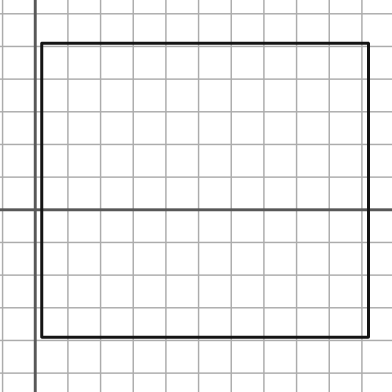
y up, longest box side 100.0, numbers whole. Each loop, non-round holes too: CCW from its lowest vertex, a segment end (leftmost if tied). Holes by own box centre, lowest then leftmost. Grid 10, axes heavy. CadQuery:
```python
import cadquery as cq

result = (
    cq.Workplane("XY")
    .moveTo(2.0, -39.0)
    .lineTo(102.0, -39.0)
    .lineTo(102.0, 51.0)
    .lineTo(2.0, 51.0)
    .close()
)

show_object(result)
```